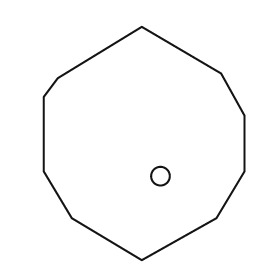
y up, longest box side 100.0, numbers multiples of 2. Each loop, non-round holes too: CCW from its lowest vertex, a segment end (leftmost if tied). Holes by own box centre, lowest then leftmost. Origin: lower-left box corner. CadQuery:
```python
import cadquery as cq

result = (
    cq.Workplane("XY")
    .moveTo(42.0, 0.0)
    .lineTo(74.0, 18.0)
    .lineTo(86.0, 38.0)
    .lineTo(86.0, 62.0)
    .lineTo(76.0, 80.0)
    .lineTo(42.0, 100.0)
    .lineTo(6.0, 78.0)
    .lineTo(0.0, 70.0)
    .lineTo(0.0, 38.0)
    .lineTo(12.0, 18.0)
    .close()
    .moveTo(50.0, 36.0)
    .circle(4.0)
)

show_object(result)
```